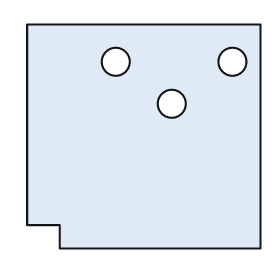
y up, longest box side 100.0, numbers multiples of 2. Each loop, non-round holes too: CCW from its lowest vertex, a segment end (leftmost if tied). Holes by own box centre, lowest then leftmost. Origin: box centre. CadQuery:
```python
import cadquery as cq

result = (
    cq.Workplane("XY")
    .moveTo(-36.0, -48.0)
    .lineTo(50.0, -48.0)
    .lineTo(50.0, 48.0)
    .lineTo(-50.0, 48.0)
    .lineTo(-50.0, -38.0)
    .lineTo(-36.0, -38.0)
    .close()
    .moveTo(12.0, 14.0)
    .circle(6.0)
    .moveTo(-12.0, 32.0)
    .circle(6.0)
    .moveTo(38.0, 32.0)
    .circle(6.0)
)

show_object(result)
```